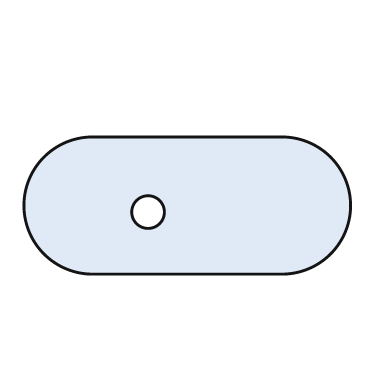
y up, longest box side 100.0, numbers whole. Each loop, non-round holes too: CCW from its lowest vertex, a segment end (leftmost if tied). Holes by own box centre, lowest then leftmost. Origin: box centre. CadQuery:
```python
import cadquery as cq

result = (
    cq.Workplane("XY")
    .moveTo(-29.0, -21.0)
    .lineTo(29.0, -21.0)
    .threePointArc((50.0, 0.0), (29.0, 21.0))
    .lineTo(-29.0, 21.0)
    .threePointArc((-50.0, 0.0), (-29.0, -21.0))
    .close()
    .moveTo(-12.0, -2.0)
    .circle(5.0)
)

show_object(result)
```